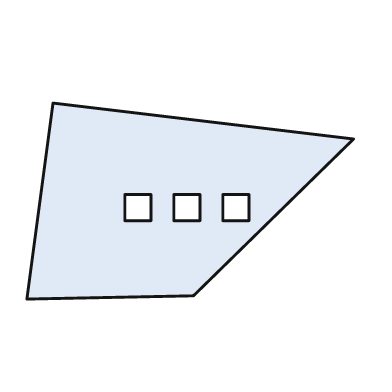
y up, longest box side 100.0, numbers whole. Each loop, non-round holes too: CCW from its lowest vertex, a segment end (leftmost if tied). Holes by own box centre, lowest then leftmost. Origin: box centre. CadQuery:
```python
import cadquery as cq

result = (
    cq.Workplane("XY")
    .moveTo(-50.0, -30.0)
    .lineTo(1.0, -29.0)
    .lineTo(50.0, 19.0)
    .lineTo(-42.0, 30.0)
    .close()
    .moveTo(-20.0, -6.0)
    .lineTo(-12.0, -6.0)
    .lineTo(-12.0, 2.0)
    .lineTo(-20.0, 2.0)
    .close()
    .moveTo(-5.0, -6.0)
    .lineTo(3.0, -6.0)
    .lineTo(3.0, 2.0)
    .lineTo(-5.0, 2.0)
    .close()
    .moveTo(10.0, -6.0)
    .lineTo(18.0, -6.0)
    .lineTo(18.0, 2.0)
    .lineTo(10.0, 2.0)
    .close()
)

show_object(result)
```